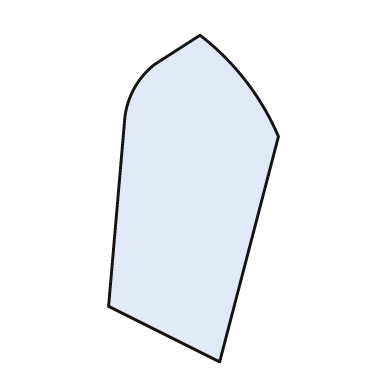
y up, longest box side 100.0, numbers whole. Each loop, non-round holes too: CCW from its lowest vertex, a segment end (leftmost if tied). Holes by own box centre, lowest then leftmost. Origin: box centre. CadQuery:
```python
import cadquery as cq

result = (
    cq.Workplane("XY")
    .moveTo(8.0, -50.0)
    .lineTo(26.0, 19.0)
    .threePointArc((16.0, 36.0), (2.0, 50.0))
    .lineTo(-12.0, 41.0)
    .threePointArc((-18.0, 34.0), (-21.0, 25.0))
    .lineTo(-26.0, -33.0)
    .close()
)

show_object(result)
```